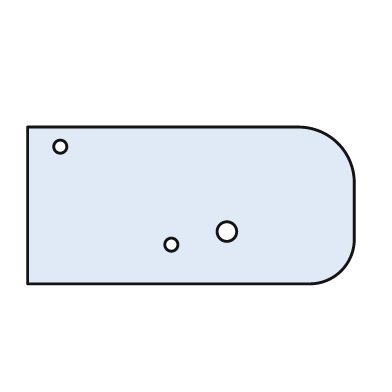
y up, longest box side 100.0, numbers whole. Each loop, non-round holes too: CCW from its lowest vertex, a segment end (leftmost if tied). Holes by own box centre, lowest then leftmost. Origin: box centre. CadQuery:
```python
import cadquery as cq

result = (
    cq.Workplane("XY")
    .moveTo(-50.0, -24.0)
    .lineTo(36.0, -24.0)
    .threePointArc((46.0, -20.0), (50.0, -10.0))
    .lineTo(50.0, 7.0)
    .threePointArc((45.0, 19.0), (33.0, 24.0))
    .lineTo(-50.0, 24.0)
    .close()
    .moveTo(-6.0, -12.0)
    .circle(2.0)
    .moveTo(11.0, -8.0)
    .circle(3.0)
    .moveTo(-40.0, 18.0)
    .circle(2.0)
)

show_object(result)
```